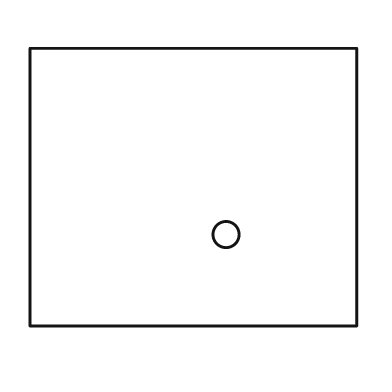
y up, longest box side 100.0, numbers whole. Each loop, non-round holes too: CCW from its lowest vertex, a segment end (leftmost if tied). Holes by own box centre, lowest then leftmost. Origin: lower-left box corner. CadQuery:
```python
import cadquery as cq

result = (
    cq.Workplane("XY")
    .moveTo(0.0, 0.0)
    .lineTo(100.0, 0.0)
    .lineTo(100.0, 85.0)
    .lineTo(0.0, 85.0)
    .close()
    .moveTo(60.0, 28.0)
    .circle(4.0)
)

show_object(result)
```